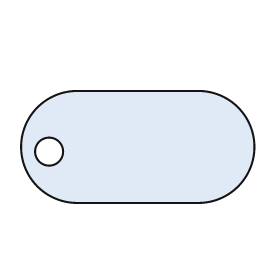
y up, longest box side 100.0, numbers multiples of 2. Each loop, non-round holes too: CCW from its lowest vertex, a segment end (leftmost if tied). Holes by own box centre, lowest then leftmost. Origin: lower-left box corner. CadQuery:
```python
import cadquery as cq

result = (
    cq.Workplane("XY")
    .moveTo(24.0, 0.0)
    .lineTo(76.0, 0.0)
    .threePointArc((100.0, 24.0), (76.0, 48.0))
    .lineTo(24.0, 48.0)
    .threePointArc((0.0, 24.0), (24.0, 0.0))
    .close()
    .moveTo(12.0, 22.0)
    .circle(6.0)
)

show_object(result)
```